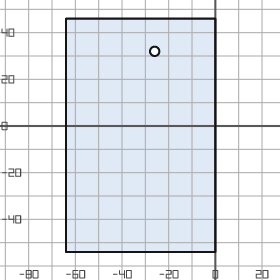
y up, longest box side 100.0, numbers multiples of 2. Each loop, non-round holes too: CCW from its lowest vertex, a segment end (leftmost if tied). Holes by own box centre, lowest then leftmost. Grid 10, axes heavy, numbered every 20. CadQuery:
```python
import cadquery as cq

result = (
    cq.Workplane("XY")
    .moveTo(-64.0, -54.0)
    .lineTo(0.0, -54.0)
    .lineTo(0.0, 46.0)
    .lineTo(-64.0, 46.0)
    .close()
    .moveTo(-26.0, 32.0)
    .circle(2.0)
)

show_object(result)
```